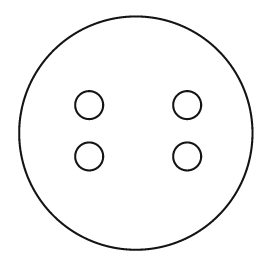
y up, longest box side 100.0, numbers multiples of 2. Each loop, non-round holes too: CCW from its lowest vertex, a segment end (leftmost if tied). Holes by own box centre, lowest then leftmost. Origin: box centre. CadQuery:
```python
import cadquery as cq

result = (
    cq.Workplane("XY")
    .moveTo(0.0, 0.0)
    .circle(50.0)
    .moveTo(-20.0, -10.0)
    .circle(6.0)
    .moveTo(22.0, -10.0)
    .circle(6.0)
    .moveTo(-20.0, 12.0)
    .circle(6.0)
    .moveTo(22.0, 12.0)
    .circle(6.0)
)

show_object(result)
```